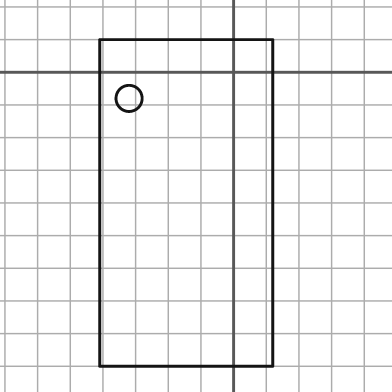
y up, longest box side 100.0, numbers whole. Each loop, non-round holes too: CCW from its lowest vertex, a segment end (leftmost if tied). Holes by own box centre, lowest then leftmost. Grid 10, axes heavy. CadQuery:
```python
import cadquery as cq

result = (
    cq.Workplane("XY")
    .moveTo(-41.0, -90.0)
    .lineTo(12.0, -90.0)
    .lineTo(12.0, 10.0)
    .lineTo(-41.0, 10.0)
    .close()
    .moveTo(-32.0, -8.0)
    .circle(4.0)
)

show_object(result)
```